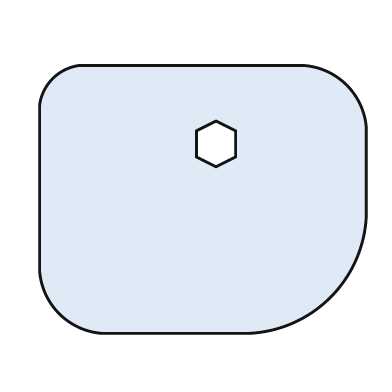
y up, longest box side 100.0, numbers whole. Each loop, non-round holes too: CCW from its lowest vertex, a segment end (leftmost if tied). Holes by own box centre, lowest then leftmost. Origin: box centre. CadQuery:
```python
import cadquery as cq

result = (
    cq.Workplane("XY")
    .moveTo(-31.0, -41.0)
    .lineTo(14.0, -41.0)
    .threePointArc((39.0, -30.0), (50.0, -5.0))
    .lineTo(50.0, 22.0)
    .threePointArc((44.0, 35.0), (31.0, 41.0))
    .lineTo(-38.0, 41.0)
    .threePointArc((-46.0, 37.0), (-50.0, 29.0))
    .lineTo(-50.0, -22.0)
    .threePointArc((-44.0, -35.0), (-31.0, -41.0))
    .close()
    .moveTo(4.0, 10.0)
    .lineTo(10.0, 13.0)
    .lineTo(10.0, 21.0)
    .lineTo(4.0, 24.0)
    .lineTo(-2.0, 21.0)
    .lineTo(-2.0, 13.0)
    .close()
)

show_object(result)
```